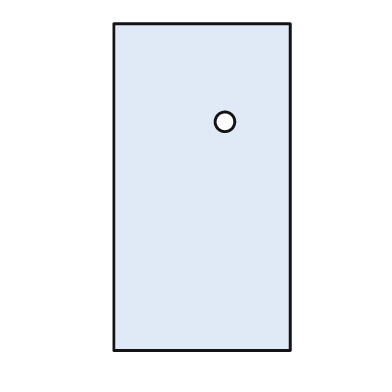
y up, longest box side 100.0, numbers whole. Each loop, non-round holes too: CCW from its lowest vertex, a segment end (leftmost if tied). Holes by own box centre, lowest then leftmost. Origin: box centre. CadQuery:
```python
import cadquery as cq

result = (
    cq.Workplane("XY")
    .moveTo(-27.0, -50.0)
    .lineTo(27.0, -50.0)
    .lineTo(27.0, 50.0)
    .lineTo(-27.0, 50.0)
    .close()
    .moveTo(7.0, 20.0)
    .circle(3.0)
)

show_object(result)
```